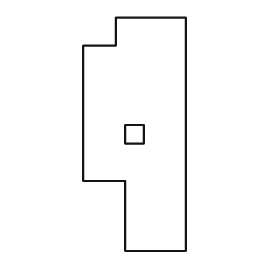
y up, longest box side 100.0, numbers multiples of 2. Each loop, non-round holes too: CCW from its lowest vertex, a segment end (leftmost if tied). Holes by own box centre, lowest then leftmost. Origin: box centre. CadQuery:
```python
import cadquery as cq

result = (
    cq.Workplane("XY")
    .moveTo(-4.0, -50.0)
    .lineTo(22.0, -50.0)
    .lineTo(22.0, 50.0)
    .lineTo(-8.0, 50.0)
    .lineTo(-8.0, 38.0)
    .lineTo(-22.0, 38.0)
    .lineTo(-22.0, -20.0)
    .lineTo(-4.0, -20.0)
    .close()
    .moveTo(-4.0, -4.0)
    .lineTo(4.0, -4.0)
    .lineTo(4.0, 4.0)
    .lineTo(-4.0, 4.0)
    .close()
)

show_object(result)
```